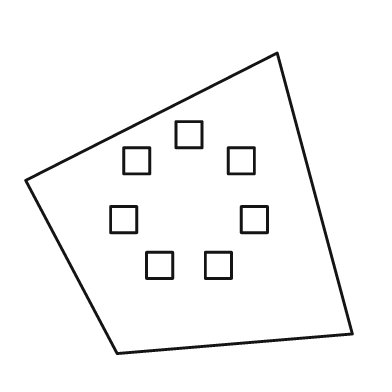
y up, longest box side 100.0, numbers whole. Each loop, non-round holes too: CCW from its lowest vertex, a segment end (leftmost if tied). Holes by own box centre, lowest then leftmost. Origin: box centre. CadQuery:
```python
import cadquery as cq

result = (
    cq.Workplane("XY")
    .moveTo(-22.0, -46.0)
    .lineTo(50.0, -40.0)
    .lineTo(27.0, 46.0)
    .lineTo(-50.0, 7.0)
    .close()
    .moveTo(-13.0, -23.0)
    .lineTo(-5.0, -23.0)
    .lineTo(-5.0, -15.0)
    .lineTo(-13.0, -15.0)
    .close()
    .moveTo(5.0, -23.0)
    .lineTo(13.0, -23.0)
    .lineTo(13.0, -15.0)
    .lineTo(5.0, -15.0)
    .close()
    .moveTo(-24.0, -9.0)
    .lineTo(-16.0, -9.0)
    .lineTo(-16.0, -1.0)
    .lineTo(-24.0, -1.0)
    .close()
    .moveTo(16.0, -9.0)
    .lineTo(24.0, -9.0)
    .lineTo(24.0, -1.0)
    .lineTo(16.0, -1.0)
    .close()
    .moveTo(-20.0, 9.0)
    .lineTo(-12.0, 9.0)
    .lineTo(-12.0, 17.0)
    .lineTo(-20.0, 17.0)
    .close()
    .moveTo(12.0, 9.0)
    .lineTo(20.0, 9.0)
    .lineTo(20.0, 17.0)
    .lineTo(12.0, 17.0)
    .close()
    .moveTo(-4.0, 17.0)
    .lineTo(4.0, 17.0)
    .lineTo(4.0, 25.0)
    .lineTo(-4.0, 25.0)
    .close()
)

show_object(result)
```